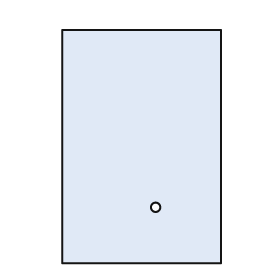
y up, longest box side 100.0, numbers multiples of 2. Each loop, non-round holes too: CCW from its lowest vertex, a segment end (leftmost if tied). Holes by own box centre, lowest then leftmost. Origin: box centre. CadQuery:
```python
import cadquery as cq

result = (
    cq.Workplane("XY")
    .moveTo(-34.0, -50.0)
    .lineTo(34.0, -50.0)
    .lineTo(34.0, 50.0)
    .lineTo(-34.0, 50.0)
    .close()
    .moveTo(6.0, -26.0)
    .circle(2.0)
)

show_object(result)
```